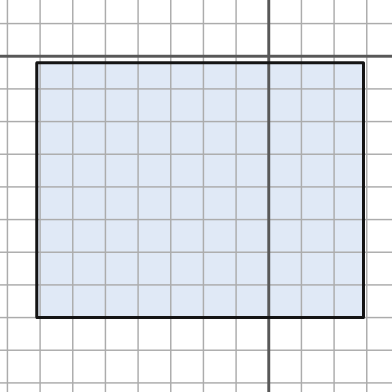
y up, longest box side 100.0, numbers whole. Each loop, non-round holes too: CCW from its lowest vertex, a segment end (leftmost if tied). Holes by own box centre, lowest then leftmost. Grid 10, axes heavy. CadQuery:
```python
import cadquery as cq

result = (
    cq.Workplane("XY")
    .moveTo(-71.0, -80.0)
    .lineTo(29.0, -80.0)
    .lineTo(29.0, -2.0)
    .lineTo(-71.0, -2.0)
    .close()
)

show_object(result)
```